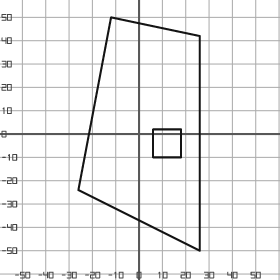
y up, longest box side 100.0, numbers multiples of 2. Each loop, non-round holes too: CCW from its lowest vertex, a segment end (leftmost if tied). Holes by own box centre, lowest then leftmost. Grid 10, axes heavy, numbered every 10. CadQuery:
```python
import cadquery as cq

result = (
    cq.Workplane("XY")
    .moveTo(26.0, -50.0)
    .lineTo(26.0, 42.0)
    .lineTo(-12.0, 50.0)
    .lineTo(-26.0, -24.0)
    .close()
    .moveTo(6.0, -10.0)
    .lineTo(18.0, -10.0)
    .lineTo(18.0, 2.0)
    .lineTo(6.0, 2.0)
    .close()
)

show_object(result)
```